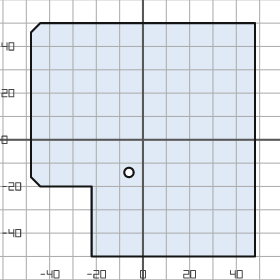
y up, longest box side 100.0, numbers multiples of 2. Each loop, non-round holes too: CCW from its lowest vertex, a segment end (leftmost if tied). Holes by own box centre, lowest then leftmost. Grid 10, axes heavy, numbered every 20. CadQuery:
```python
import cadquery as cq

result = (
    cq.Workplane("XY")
    .moveTo(-22.0, -50.0)
    .lineTo(48.0, -50.0)
    .lineTo(48.0, 50.0)
    .lineTo(-44.0, 50.0)
    .lineTo(-48.0, 46.0)
    .lineTo(-48.0, -16.0)
    .lineTo(-44.0, -20.0)
    .lineTo(-22.0, -20.0)
    .close()
    .moveTo(-6.0, -14.0)
    .circle(2.0)
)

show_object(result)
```